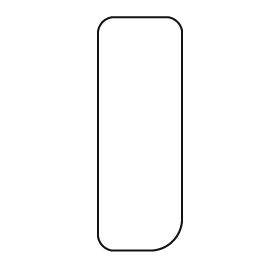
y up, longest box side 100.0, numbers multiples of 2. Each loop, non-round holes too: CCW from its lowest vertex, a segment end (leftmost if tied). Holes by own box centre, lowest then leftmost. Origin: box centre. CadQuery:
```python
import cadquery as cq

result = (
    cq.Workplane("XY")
    .moveTo(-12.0, -50.0)
    .lineTo(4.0, -50.0)
    .threePointArc((14.0, -46.0), (18.0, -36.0))
    .lineTo(18.0, 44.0)
    .threePointArc((16.0, 48.0), (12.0, 50.0))
    .lineTo(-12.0, 50.0)
    .threePointArc((-16.0, 48.0), (-18.0, 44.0))
    .lineTo(-18.0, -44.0)
    .threePointArc((-16.0, -48.0), (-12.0, -50.0))
    .close()
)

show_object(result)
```